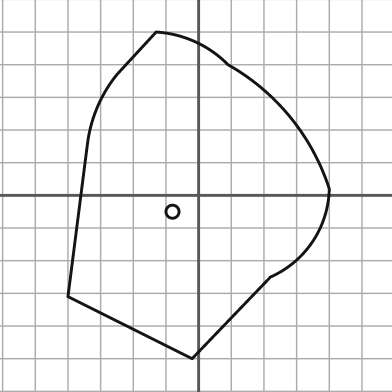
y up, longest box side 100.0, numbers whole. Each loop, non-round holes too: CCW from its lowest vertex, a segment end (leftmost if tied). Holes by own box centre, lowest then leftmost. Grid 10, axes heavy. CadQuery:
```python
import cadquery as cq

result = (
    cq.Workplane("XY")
    .moveTo(-2.0, -50.0)
    .lineTo(22.0, -25.0)
    .threePointArc((35.0, -14.0), (40.0, 2.0))
    .threePointArc((28.0, 24.0), (9.0, 40.0))
    .threePointArc((-1.0, 47.0), (-13.0, 50.0))
    .lineTo(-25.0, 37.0)
    .threePointArc((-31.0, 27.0), (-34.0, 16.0))
    .lineTo(-40.0, -31.0)
    .close()
    .moveTo(-8.0, -5.0)
    .circle(2.0)
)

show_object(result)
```